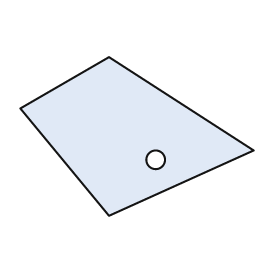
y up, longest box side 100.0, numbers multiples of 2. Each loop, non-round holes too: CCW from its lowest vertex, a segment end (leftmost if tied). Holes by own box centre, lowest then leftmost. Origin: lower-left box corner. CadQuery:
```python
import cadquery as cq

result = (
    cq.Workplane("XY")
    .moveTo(38.0, 0.0)
    .lineTo(100.0, 28.0)
    .lineTo(38.0, 68.0)
    .lineTo(0.0, 46.0)
    .close()
    .moveTo(58.0, 24.0)
    .circle(4.0)
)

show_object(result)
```